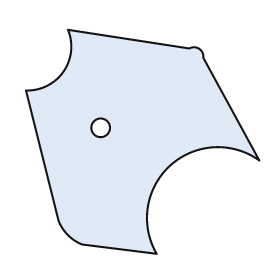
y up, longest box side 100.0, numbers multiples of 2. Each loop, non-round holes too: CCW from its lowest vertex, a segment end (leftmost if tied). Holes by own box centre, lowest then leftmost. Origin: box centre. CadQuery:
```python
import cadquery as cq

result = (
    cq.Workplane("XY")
    .moveTo(6.0, -48.0)
    .threePointArc((12.0, -10.0), (50.0, -8.0))
    .lineTo(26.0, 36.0)
    .threePointArc((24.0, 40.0), (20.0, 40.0))
    .lineTo(-32.0, 48.0)
    .threePointArc((-34.0, 30.0), (-50.0, 22.0))
    .lineTo(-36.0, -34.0)
    .threePointArc((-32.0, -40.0), (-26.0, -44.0))
    .close()
    .moveTo(-18.0, 6.0)
    .circle(4.0)
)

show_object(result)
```